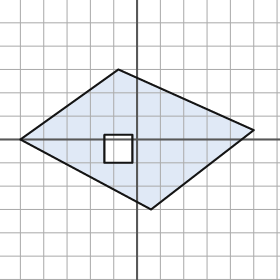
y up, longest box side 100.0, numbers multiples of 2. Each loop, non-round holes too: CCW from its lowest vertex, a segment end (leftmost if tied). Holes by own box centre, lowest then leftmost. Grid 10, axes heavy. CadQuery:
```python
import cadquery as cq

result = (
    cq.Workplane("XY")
    .moveTo(6.0, -30.0)
    .lineTo(50.0, 4.0)
    .lineTo(-8.0, 30.0)
    .lineTo(-50.0, 0.0)
    .close()
    .moveTo(-14.0, -10.0)
    .lineTo(-2.0, -10.0)
    .lineTo(-2.0, 2.0)
    .lineTo(-14.0, 2.0)
    .close()
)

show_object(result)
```